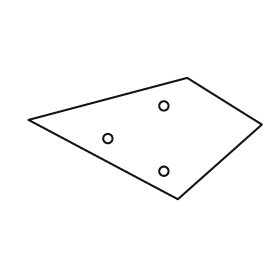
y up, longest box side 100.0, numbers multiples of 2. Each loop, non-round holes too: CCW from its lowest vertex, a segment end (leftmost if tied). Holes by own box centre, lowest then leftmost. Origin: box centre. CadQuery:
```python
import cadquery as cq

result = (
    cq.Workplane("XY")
    .moveTo(14.0, -26.0)
    .lineTo(50.0, 6.0)
    .lineTo(18.0, 26.0)
    .lineTo(-50.0, 8.0)
    .close()
    .moveTo(8.0, -14.0)
    .circle(2.0)
    .moveTo(-16.0, 0.0)
    .circle(2.0)
    .moveTo(8.0, 14.0)
    .circle(2.0)
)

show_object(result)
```